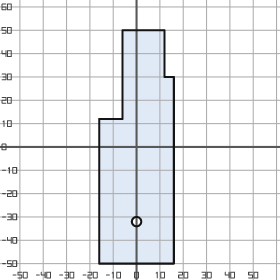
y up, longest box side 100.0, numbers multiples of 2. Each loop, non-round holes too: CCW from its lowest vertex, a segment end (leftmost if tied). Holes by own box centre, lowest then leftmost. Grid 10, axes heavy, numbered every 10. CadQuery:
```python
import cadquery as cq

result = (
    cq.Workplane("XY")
    .moveTo(-16.0, -50.0)
    .lineTo(16.0, -50.0)
    .lineTo(16.0, 30.0)
    .lineTo(12.0, 30.0)
    .lineTo(12.0, 50.0)
    .lineTo(-6.0, 50.0)
    .lineTo(-6.0, 12.0)
    .lineTo(-16.0, 12.0)
    .close()
    .moveTo(0.0, -32.0)
    .circle(2.0)
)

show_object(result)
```